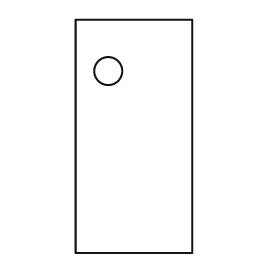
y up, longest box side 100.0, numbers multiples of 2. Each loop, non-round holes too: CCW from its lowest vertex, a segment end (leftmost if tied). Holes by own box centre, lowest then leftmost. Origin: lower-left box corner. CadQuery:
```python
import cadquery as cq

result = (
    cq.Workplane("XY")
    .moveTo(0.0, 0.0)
    .lineTo(50.0, 0.0)
    .lineTo(50.0, 100.0)
    .lineTo(0.0, 100.0)
    .close()
    .moveTo(14.0, 78.0)
    .circle(6.0)
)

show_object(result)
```